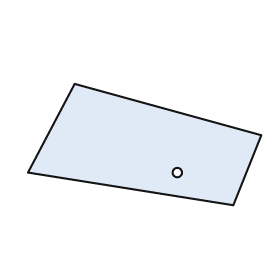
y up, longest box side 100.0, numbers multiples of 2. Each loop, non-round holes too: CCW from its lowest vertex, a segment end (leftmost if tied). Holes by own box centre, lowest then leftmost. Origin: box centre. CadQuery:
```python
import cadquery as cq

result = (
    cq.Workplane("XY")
    .moveTo(38.0, -26.0)
    .lineTo(50.0, 4.0)
    .lineTo(-30.0, 26.0)
    .lineTo(-50.0, -12.0)
    .close()
    .moveTo(14.0, -12.0)
    .circle(2.0)
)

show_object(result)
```